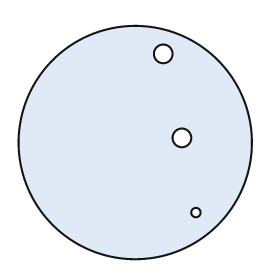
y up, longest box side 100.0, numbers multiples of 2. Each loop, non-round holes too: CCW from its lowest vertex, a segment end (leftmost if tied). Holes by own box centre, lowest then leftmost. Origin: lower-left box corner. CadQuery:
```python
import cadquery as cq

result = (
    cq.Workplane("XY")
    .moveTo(50.0, 50.0)
    .circle(50.0)
    .moveTo(76.0, 20.0)
    .circle(2.0)
    .moveTo(70.0, 52.0)
    .circle(4.0)
    .moveTo(62.0, 88.0)
    .circle(4.0)
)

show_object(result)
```